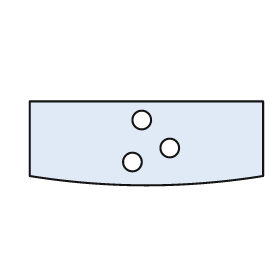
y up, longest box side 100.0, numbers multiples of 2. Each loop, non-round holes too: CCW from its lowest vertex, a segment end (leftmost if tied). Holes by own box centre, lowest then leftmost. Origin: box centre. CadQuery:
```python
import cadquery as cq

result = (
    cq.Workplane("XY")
    .moveTo(-50.0, -14.0)
    .threePointArc((0.0, -18.0), (50.0, -14.0))
    .lineTo(50.0, 18.0)
    .lineTo(-50.0, 18.0)
    .close()
    .moveTo(-6.0, -8.0)
    .circle(4.0)
    .moveTo(10.0, -2.0)
    .circle(4.0)
    .moveTo(-2.0, 10.0)
    .circle(4.0)
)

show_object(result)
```